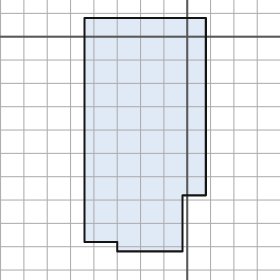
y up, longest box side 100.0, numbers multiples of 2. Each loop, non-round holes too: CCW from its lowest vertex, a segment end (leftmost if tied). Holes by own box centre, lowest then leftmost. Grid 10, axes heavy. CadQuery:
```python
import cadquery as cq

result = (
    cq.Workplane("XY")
    .moveTo(-30.0, -92.0)
    .lineTo(-2.0, -92.0)
    .lineTo(-2.0, -68.0)
    .lineTo(8.0, -68.0)
    .lineTo(8.0, 8.0)
    .lineTo(-44.0, 8.0)
    .lineTo(-44.0, -88.0)
    .lineTo(-30.0, -88.0)
    .close()
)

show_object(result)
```